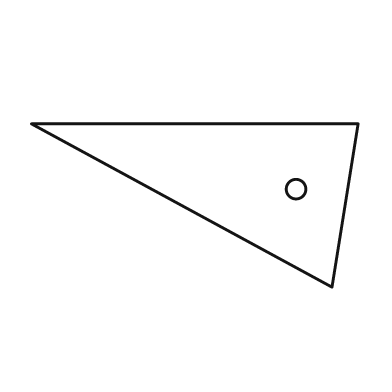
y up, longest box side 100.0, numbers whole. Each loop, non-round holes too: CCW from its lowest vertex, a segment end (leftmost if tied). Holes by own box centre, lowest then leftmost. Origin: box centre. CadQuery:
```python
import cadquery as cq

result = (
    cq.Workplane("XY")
    .moveTo(42.0, -25.0)
    .lineTo(50.0, 25.0)
    .lineTo(-50.0, 25.0)
    .close()
    .moveTo(31.0, 5.0)
    .circle(3.0)
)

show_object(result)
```